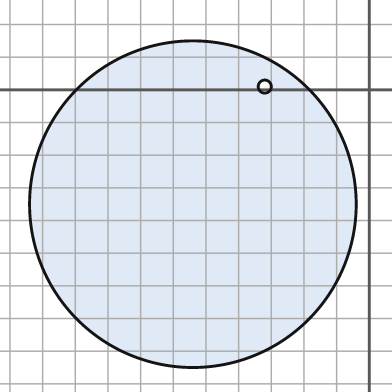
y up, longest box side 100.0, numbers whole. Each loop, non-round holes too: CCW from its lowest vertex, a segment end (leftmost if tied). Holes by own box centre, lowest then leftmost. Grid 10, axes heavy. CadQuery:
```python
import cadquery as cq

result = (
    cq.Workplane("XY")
    .moveTo(-54.0, -35.0)
    .circle(50.0)
    .moveTo(-32.0, 1.0)
    .circle(2.0)
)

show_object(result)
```